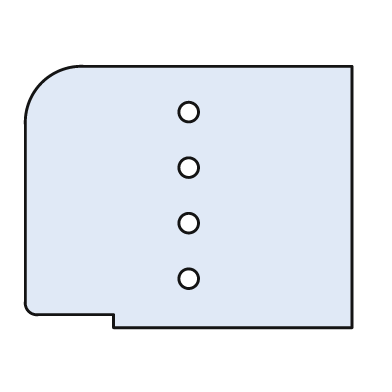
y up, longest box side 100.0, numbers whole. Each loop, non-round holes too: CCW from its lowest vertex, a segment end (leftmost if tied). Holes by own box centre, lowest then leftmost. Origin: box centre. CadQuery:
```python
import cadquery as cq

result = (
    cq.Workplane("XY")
    .moveTo(-23.0, -40.0)
    .lineTo(50.0, -40.0)
    .lineTo(50.0, 40.0)
    .lineTo(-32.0, 40.0)
    .threePointArc((-45.0, 35.0), (-50.0, 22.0))
    .lineTo(-50.0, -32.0)
    .threePointArc((-49.0, -35.0), (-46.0, -36.0))
    .lineTo(-23.0, -36.0)
    .close()
    .moveTo(0.0, -25.0)
    .circle(3.0)
    .moveTo(0.0, -8.0)
    .circle(3.0)
    .moveTo(0.0, 9.0)
    .circle(3.0)
    .moveTo(0.0, 26.0)
    .circle(3.0)
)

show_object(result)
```